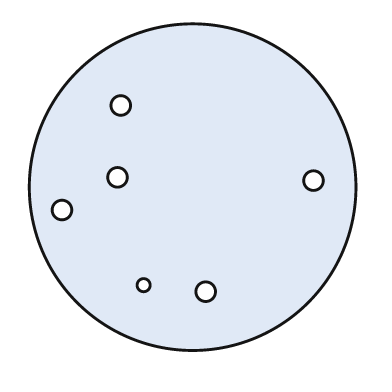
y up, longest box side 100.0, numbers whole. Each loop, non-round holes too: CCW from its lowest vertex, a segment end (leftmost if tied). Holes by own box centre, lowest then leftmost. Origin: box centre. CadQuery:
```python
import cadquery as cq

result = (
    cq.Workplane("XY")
    .moveTo(0.0, 0.0)
    .circle(50.0)
    .moveTo(4.0, -32.0)
    .circle(3.0)
    .moveTo(-15.0, -30.0)
    .circle(2.0)
    .moveTo(-40.0, -7.0)
    .circle(3.0)
    .moveTo(37.0, 2.0)
    .circle(3.0)
    .moveTo(-23.0, 3.0)
    .circle(3.0)
    .moveTo(-22.0, 25.0)
    .circle(3.0)
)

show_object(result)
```